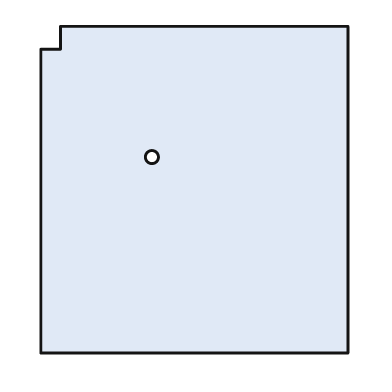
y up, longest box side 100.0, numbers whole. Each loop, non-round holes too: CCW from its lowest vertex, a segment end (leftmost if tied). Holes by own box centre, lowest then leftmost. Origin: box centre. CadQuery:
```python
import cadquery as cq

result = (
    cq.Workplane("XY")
    .moveTo(-47.0, -50.0)
    .lineTo(47.0, -50.0)
    .lineTo(47.0, 50.0)
    .lineTo(-41.0, 50.0)
    .lineTo(-41.0, 43.0)
    .lineTo(-47.0, 43.0)
    .close()
    .moveTo(-13.0, 10.0)
    .circle(2.0)
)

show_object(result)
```